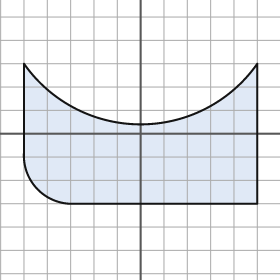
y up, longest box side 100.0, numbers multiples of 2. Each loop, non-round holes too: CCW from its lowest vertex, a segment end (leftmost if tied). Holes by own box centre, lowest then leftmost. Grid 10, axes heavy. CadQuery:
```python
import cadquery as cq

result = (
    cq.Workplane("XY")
    .moveTo(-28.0, -30.0)
    .lineTo(50.0, -30.0)
    .lineTo(50.0, 30.0)
    .threePointArc((0.0, 4.0), (-50.0, 30.0))
    .lineTo(-50.0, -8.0)
    .threePointArc((-44.0, -24.0), (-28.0, -30.0))
    .close()
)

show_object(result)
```